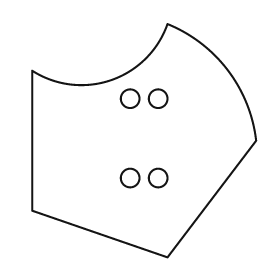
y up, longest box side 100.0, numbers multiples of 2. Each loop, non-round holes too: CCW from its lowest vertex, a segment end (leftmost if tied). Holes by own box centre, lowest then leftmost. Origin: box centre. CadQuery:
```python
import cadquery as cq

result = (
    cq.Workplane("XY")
    .moveTo(10.0, -50.0)
    .lineTo(48.0, 0.0)
    .threePointArc((36.0, 30.0), (10.0, 50.0))
    .threePointArc((-14.0, 26.0), (-48.0, 30.0))
    .lineTo(-48.0, -30.0)
    .close()
    .moveTo(-6.0, -16.0)
    .circle(4.0)
    .moveTo(6.0, -16.0)
    .circle(4.0)
    .moveTo(-6.0, 18.0)
    .circle(4.0)
    .moveTo(6.0, 18.0)
    .circle(4.0)
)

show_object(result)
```